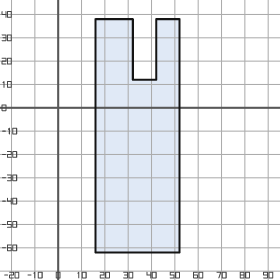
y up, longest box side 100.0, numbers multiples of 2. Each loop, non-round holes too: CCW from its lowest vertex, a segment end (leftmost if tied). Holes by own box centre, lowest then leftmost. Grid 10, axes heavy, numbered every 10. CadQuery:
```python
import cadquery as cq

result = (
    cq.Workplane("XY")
    .moveTo(16.0, -62.0)
    .lineTo(52.0, -62.0)
    .lineTo(52.0, 38.0)
    .lineTo(42.0, 38.0)
    .lineTo(42.0, 12.0)
    .lineTo(32.0, 12.0)
    .lineTo(32.0, 38.0)
    .lineTo(16.0, 38.0)
    .close()
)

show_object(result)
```